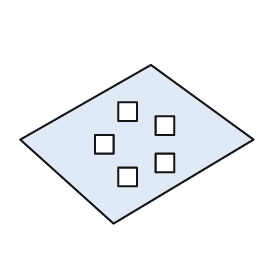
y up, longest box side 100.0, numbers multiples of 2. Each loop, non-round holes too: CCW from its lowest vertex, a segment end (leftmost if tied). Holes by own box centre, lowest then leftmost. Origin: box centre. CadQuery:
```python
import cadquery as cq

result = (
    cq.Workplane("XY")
    .moveTo(-10.0, -34.0)
    .lineTo(50.0, 2.0)
    .lineTo(6.0, 34.0)
    .lineTo(-50.0, 2.0)
    .close()
    .moveTo(-8.0, -18.0)
    .lineTo(0.0, -18.0)
    .lineTo(0.0, -10.0)
    .lineTo(-8.0, -10.0)
    .close()
    .moveTo(8.0, -12.0)
    .lineTo(16.0, -12.0)
    .lineTo(16.0, -4.0)
    .lineTo(8.0, -4.0)
    .close()
    .moveTo(-18.0, -4.0)
    .lineTo(-10.0, -4.0)
    .lineTo(-10.0, 4.0)
    .lineTo(-18.0, 4.0)
    .close()
    .moveTo(8.0, 4.0)
    .lineTo(16.0, 4.0)
    .lineTo(16.0, 12.0)
    .lineTo(8.0, 12.0)
    .close()
    .moveTo(-8.0, 10.0)
    .lineTo(0.0, 10.0)
    .lineTo(0.0, 18.0)
    .lineTo(-8.0, 18.0)
    .close()
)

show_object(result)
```